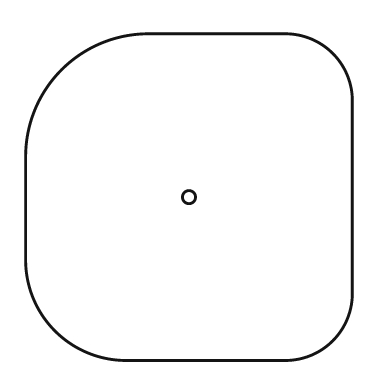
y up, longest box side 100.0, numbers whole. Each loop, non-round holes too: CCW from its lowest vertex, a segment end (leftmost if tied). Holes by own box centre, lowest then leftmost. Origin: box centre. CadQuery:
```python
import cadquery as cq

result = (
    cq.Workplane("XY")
    .moveTo(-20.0, -50.0)
    .lineTo(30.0, -50.0)
    .threePointArc((44.0, -44.0), (50.0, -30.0))
    .lineTo(50.0, 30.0)
    .threePointArc((44.0, 44.0), (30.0, 50.0))
    .lineTo(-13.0, 50.0)
    .threePointArc((-39.0, 39.0), (-50.0, 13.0))
    .lineTo(-50.0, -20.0)
    .threePointArc((-41.0, -41.0), (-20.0, -50.0))
    .close()
    .moveTo(0.0, 0.0)
    .circle(2.0)
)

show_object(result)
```